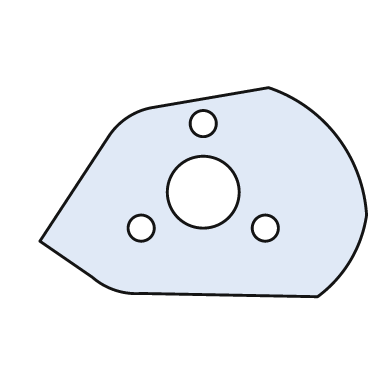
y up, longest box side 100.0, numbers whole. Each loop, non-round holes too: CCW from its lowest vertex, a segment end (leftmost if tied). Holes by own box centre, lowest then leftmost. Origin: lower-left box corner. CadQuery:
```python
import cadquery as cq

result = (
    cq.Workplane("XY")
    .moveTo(85.0, 0.0)
    .threePointArc((95.0, 11.0), (100.0, 25.0))
    .threePointArc((91.0, 49.0), (70.0, 64.0))
    .lineTo(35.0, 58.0)
    .threePointArc((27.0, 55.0), (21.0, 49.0))
    .lineTo(0.0, 17.0)
    .lineTo(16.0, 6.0)
    .threePointArc((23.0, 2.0), (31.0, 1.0))
    .close()
    .moveTo(31.0, 21.0)
    .circle(4.0)
    .moveTo(69.0, 21.0)
    .circle(4.0)
    .moveTo(50.0, 32.0)
    .circle(11.0)
    .moveTo(50.0, 53.0)
    .circle(4.0)
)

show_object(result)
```